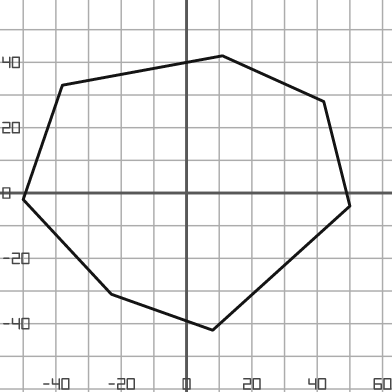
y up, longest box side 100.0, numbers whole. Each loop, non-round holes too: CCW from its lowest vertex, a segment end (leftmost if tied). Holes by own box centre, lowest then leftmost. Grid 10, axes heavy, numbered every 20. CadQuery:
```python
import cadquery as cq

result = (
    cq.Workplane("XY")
    .moveTo(8.0, -42.0)
    .lineTo(50.0, -4.0)
    .lineTo(42.0, 28.0)
    .lineTo(11.0, 42.0)
    .lineTo(-38.0, 33.0)
    .lineTo(-50.0, -2.0)
    .lineTo(-23.0, -31.0)
    .close()
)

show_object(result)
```